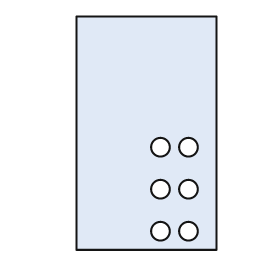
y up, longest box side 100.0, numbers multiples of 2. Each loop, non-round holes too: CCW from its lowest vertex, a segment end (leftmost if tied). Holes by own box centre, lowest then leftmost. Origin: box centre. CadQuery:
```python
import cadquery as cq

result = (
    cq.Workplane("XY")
    .moveTo(-30.0, -50.0)
    .lineTo(30.0, -50.0)
    .lineTo(30.0, 50.0)
    .lineTo(-30.0, 50.0)
    .close()
    .moveTo(6.0, -42.0)
    .circle(4.0)
    .moveTo(18.0, -42.0)
    .circle(4.0)
    .moveTo(6.0, -24.0)
    .circle(4.0)
    .moveTo(18.0, -24.0)
    .circle(4.0)
    .moveTo(6.0, -6.0)
    .circle(4.0)
    .moveTo(18.0, -6.0)
    .circle(4.0)
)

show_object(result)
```